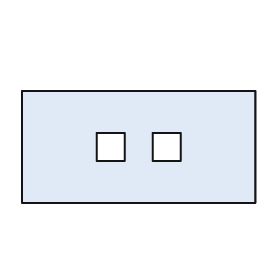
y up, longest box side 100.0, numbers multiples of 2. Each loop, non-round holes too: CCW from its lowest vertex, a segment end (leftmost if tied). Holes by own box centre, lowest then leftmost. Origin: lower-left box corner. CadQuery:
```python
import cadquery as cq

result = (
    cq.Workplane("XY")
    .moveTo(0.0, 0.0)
    .lineTo(100.0, 0.0)
    .lineTo(100.0, 48.0)
    .lineTo(0.0, 48.0)
    .close()
    .moveTo(32.0, 18.0)
    .lineTo(44.0, 18.0)
    .lineTo(44.0, 30.0)
    .lineTo(32.0, 30.0)
    .close()
    .moveTo(56.0, 18.0)
    .lineTo(68.0, 18.0)
    .lineTo(68.0, 30.0)
    .lineTo(56.0, 30.0)
    .close()
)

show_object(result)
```